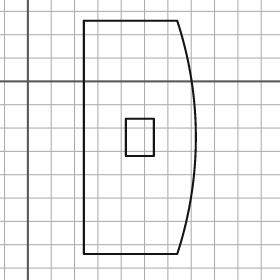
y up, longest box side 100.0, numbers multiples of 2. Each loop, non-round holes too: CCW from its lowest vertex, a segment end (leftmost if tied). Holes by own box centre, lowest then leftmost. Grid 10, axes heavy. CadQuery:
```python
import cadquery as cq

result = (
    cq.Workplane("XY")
    .moveTo(24.0, -74.0)
    .lineTo(64.0, -74.0)
    .threePointArc((72.0, -24.0), (64.0, 26.0))
    .lineTo(24.0, 26.0)
    .close()
    .moveTo(42.0, -32.0)
    .lineTo(54.0, -32.0)
    .lineTo(54.0, -16.0)
    .lineTo(42.0, -16.0)
    .close()
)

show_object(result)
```